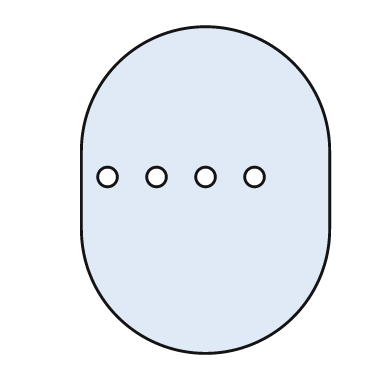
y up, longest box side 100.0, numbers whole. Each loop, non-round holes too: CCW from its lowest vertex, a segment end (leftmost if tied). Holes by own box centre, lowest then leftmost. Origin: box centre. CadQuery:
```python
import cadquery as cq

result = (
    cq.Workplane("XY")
    .moveTo(-38.0, -12.0)
    .threePointArc((0.0, -50.0), (38.0, -12.0))
    .lineTo(38.0, 12.0)
    .threePointArc((0.0, 50.0), (-38.0, 12.0))
    .close()
    .moveTo(-30.0, 4.0)
    .circle(3.0)
    .moveTo(-15.0, 4.0)
    .circle(3.0)
    .moveTo(0.0, 4.0)
    .circle(3.0)
    .moveTo(15.0, 4.0)
    .circle(3.0)
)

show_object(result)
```